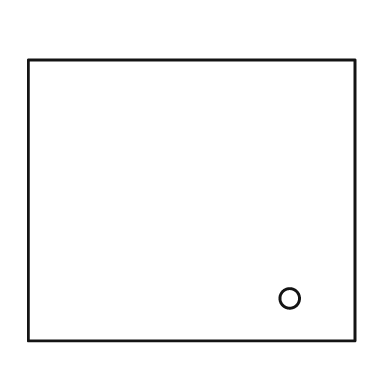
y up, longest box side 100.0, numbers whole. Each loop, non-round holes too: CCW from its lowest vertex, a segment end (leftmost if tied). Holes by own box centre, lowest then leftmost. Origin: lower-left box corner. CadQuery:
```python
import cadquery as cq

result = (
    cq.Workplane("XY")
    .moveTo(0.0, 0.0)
    .lineTo(100.0, 0.0)
    .lineTo(100.0, 86.0)
    .lineTo(0.0, 86.0)
    .close()
    .moveTo(80.0, 13.0)
    .circle(3.0)
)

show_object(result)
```